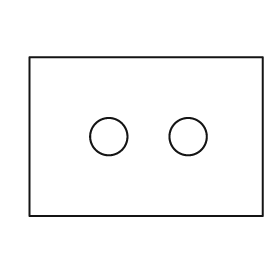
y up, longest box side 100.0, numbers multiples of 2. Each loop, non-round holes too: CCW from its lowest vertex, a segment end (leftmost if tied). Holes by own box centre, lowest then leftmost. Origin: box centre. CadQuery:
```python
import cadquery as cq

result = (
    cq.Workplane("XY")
    .moveTo(-50.0, -34.0)
    .lineTo(50.0, -34.0)
    .lineTo(50.0, 34.0)
    .lineTo(-50.0, 34.0)
    .close()
    .moveTo(-16.0, 0.0)
    .circle(8.0)
    .moveTo(18.0, 0.0)
    .circle(8.0)
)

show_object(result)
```